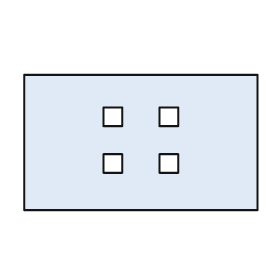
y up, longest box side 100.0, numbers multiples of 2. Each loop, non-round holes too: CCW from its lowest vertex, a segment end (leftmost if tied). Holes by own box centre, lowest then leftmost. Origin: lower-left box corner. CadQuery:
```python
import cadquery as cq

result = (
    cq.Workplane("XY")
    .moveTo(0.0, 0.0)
    .lineTo(100.0, 0.0)
    .lineTo(100.0, 58.0)
    .lineTo(0.0, 58.0)
    .close()
    .moveTo(34.0, 16.0)
    .lineTo(42.0, 16.0)
    .lineTo(42.0, 24.0)
    .lineTo(34.0, 24.0)
    .close()
    .moveTo(58.0, 16.0)
    .lineTo(66.0, 16.0)
    .lineTo(66.0, 24.0)
    .lineTo(58.0, 24.0)
    .close()
    .moveTo(34.0, 36.0)
    .lineTo(42.0, 36.0)
    .lineTo(42.0, 44.0)
    .lineTo(34.0, 44.0)
    .close()
    .moveTo(58.0, 36.0)
    .lineTo(66.0, 36.0)
    .lineTo(66.0, 44.0)
    .lineTo(58.0, 44.0)
    .close()
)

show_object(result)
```